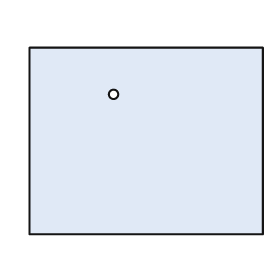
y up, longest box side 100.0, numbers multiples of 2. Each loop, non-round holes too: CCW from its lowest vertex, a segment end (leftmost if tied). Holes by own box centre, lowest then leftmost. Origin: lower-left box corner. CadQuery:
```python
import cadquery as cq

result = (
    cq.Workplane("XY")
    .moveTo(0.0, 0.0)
    .lineTo(100.0, 0.0)
    .lineTo(100.0, 80.0)
    .lineTo(0.0, 80.0)
    .close()
    .moveTo(36.0, 60.0)
    .circle(2.0)
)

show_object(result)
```